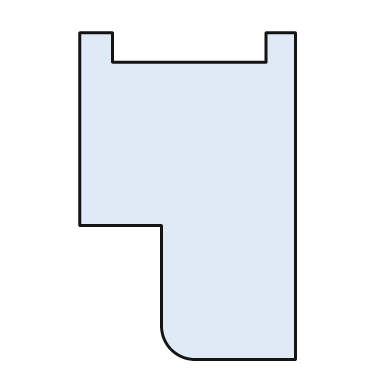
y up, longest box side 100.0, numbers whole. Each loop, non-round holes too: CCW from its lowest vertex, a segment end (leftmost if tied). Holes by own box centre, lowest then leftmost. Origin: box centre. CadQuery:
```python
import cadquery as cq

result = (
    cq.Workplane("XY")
    .moveTo(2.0, -50.0)
    .lineTo(33.0, -50.0)
    .lineTo(33.0, 50.0)
    .lineTo(24.0, 50.0)
    .lineTo(24.0, 41.0)
    .lineTo(-23.0, 41.0)
    .lineTo(-23.0, 50.0)
    .lineTo(-33.0, 50.0)
    .lineTo(-33.0, -9.0)
    .lineTo(-8.0, -9.0)
    .lineTo(-8.0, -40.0)
    .threePointArc((-5.0, -47.0), (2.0, -50.0))
    .close()
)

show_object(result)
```